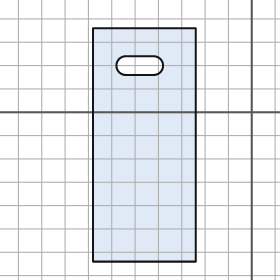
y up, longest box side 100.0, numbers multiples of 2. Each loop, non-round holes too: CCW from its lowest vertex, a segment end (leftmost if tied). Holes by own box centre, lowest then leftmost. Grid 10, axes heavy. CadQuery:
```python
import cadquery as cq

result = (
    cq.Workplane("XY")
    .moveTo(-68.0, -64.0)
    .lineTo(-24.0, -64.0)
    .lineTo(-24.0, 36.0)
    .lineTo(-68.0, 36.0)
    .close()
    .moveTo(-54.0, 16.0)
    .lineTo(-42.0, 16.0)
    .threePointArc((-38.0, 20.0), (-42.0, 24.0))
    .lineTo(-54.0, 24.0)
    .threePointArc((-58.0, 20.0), (-54.0, 16.0))
    .close()
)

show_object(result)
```